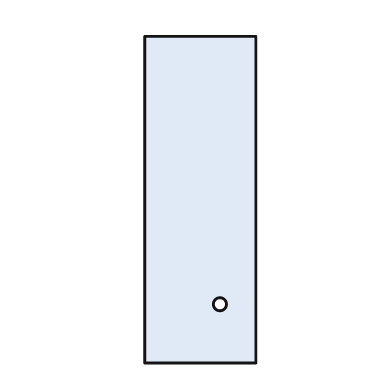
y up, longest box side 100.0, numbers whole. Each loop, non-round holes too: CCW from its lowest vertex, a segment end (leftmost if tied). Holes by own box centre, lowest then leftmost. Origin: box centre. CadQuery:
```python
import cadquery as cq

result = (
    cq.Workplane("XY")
    .moveTo(-17.0, -50.0)
    .lineTo(17.0, -50.0)
    .lineTo(17.0, 50.0)
    .lineTo(-17.0, 50.0)
    .close()
    .moveTo(6.0, -32.0)
    .circle(2.0)
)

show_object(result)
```